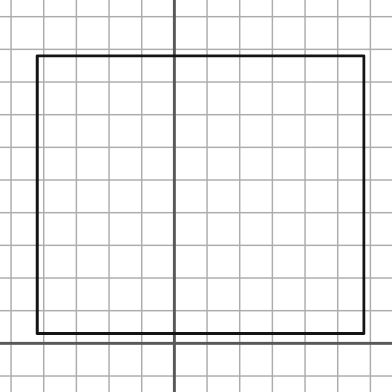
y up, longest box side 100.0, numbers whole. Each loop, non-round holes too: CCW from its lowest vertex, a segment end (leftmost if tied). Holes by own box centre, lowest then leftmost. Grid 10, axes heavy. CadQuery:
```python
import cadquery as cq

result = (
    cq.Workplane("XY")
    .moveTo(-42.0, 3.0)
    .lineTo(58.0, 3.0)
    .lineTo(58.0, 88.0)
    .lineTo(-42.0, 88.0)
    .close()
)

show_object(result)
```